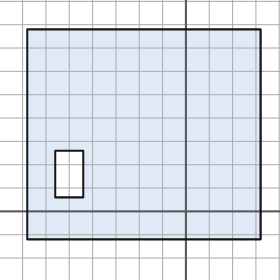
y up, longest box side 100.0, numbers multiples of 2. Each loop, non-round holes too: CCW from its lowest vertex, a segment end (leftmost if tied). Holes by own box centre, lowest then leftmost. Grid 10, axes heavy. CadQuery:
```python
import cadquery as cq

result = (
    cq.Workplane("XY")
    .moveTo(-68.0, -12.0)
    .lineTo(32.0, -12.0)
    .lineTo(32.0, 78.0)
    .lineTo(-68.0, 78.0)
    .close()
    .moveTo(-56.0, 6.0)
    .lineTo(-44.0, 6.0)
    .lineTo(-44.0, 26.0)
    .lineTo(-56.0, 26.0)
    .close()
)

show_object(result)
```